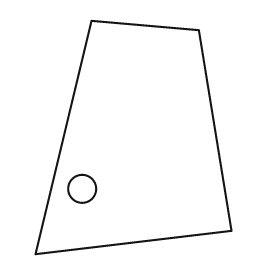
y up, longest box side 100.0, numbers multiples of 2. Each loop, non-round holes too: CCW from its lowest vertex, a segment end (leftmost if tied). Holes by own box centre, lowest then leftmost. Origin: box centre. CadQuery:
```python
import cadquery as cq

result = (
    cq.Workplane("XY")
    .moveTo(-42.0, -50.0)
    .lineTo(42.0, -40.0)
    .lineTo(28.0, 46.0)
    .lineTo(-18.0, 50.0)
    .close()
    .moveTo(-22.0, -22.0)
    .circle(6.0)
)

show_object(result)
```